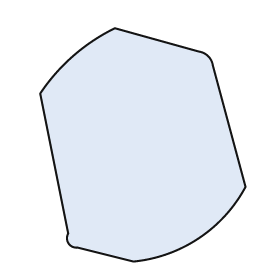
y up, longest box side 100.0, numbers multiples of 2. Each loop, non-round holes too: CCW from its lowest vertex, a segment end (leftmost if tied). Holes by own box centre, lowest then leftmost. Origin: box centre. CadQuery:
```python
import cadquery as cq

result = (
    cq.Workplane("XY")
    .moveTo(-4.0, -50.0)
    .threePointArc((24.0, -40.0), (44.0, -18.0))
    .lineTo(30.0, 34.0)
    .threePointArc((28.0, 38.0), (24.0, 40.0))
    .lineTo(-12.0, 50.0)
    .threePointArc((-30.0, 38.0), (-44.0, 22.0))
    .lineTo(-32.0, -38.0)
    .threePointArc((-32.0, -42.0), (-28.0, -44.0))
    .close()
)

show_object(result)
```